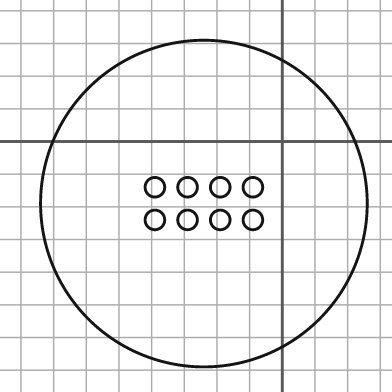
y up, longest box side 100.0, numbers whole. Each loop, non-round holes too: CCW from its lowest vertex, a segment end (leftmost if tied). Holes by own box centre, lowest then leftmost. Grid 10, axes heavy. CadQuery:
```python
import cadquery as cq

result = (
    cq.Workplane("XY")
    .moveTo(-24.0, -19.0)
    .circle(50.0)
    .moveTo(-39.0, -24.0)
    .circle(3.0)
    .moveTo(-29.0, -24.0)
    .circle(3.0)
    .moveTo(-19.0, -24.0)
    .circle(3.0)
    .moveTo(-9.0, -24.0)
    .circle(3.0)
    .moveTo(-39.0, -14.0)
    .circle(3.0)
    .moveTo(-29.0, -14.0)
    .circle(3.0)
    .moveTo(-19.0, -14.0)
    .circle(3.0)
    .moveTo(-9.0, -14.0)
    .circle(3.0)
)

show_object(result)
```